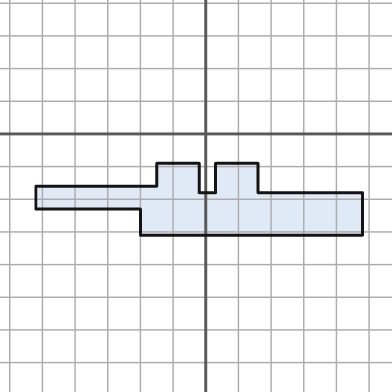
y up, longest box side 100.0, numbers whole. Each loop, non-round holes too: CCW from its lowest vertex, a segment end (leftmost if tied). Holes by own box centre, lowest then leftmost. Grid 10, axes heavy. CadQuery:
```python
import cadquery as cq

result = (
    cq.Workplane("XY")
    .moveTo(-20.0, -31.0)
    .lineTo(48.0, -31.0)
    .lineTo(48.0, -18.0)
    .lineTo(16.0, -18.0)
    .lineTo(16.0, -9.0)
    .lineTo(3.0, -9.0)
    .lineTo(3.0, -18.0)
    .lineTo(-2.0, -18.0)
    .lineTo(-2.0, -9.0)
    .lineTo(-15.0, -9.0)
    .lineTo(-15.0, -16.0)
    .lineTo(-52.0, -16.0)
    .lineTo(-52.0, -23.0)
    .lineTo(-20.0, -23.0)
    .close()
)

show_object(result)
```